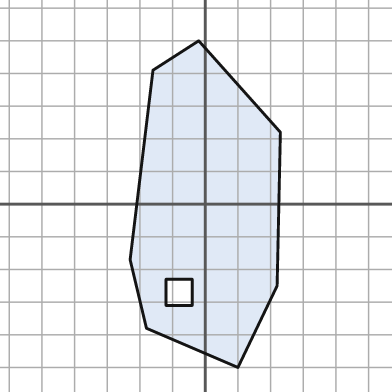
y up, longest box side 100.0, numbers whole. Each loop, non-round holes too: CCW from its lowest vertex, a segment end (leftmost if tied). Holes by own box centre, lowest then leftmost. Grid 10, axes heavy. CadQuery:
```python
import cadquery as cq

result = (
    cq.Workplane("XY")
    .moveTo(10.0, -50.0)
    .lineTo(22.0, -25.0)
    .lineTo(23.0, 22.0)
    .lineTo(-2.0, 50.0)
    .lineTo(-16.0, 41.0)
    .lineTo(-23.0, -17.0)
    .lineTo(-18.0, -38.0)
    .close()
    .moveTo(-12.0, -31.0)
    .lineTo(-4.0, -31.0)
    .lineTo(-4.0, -23.0)
    .lineTo(-12.0, -23.0)
    .close()
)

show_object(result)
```